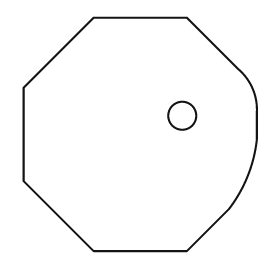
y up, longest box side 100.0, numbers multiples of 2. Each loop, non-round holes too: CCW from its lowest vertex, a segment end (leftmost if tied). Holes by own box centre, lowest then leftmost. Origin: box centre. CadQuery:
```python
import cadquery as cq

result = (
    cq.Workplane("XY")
    .moveTo(-20.0, -50.0)
    .lineTo(20.0, -50.0)
    .lineTo(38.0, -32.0)
    .threePointArc((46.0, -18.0), (50.0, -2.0))
    .lineTo(50.0, 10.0)
    .threePointArc((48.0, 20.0), (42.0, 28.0))
    .lineTo(20.0, 50.0)
    .lineTo(-20.0, 50.0)
    .lineTo(-50.0, 20.0)
    .lineTo(-50.0, -20.0)
    .close()
    .moveTo(18.0, 8.0)
    .circle(6.0)
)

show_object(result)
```